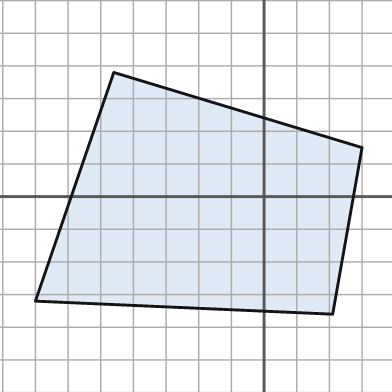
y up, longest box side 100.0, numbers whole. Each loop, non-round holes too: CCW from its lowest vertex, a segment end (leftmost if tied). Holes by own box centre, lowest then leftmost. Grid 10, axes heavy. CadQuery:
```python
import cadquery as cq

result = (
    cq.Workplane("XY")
    .moveTo(21.0, -36.0)
    .lineTo(30.0, 15.0)
    .lineTo(-46.0, 38.0)
    .lineTo(-70.0, -32.0)
    .close()
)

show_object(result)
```